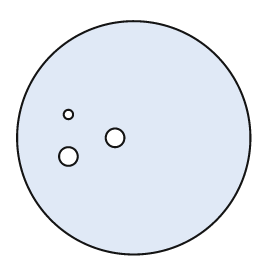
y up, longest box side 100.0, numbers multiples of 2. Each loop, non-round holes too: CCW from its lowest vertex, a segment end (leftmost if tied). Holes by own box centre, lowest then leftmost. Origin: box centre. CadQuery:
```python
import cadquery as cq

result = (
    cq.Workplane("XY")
    .moveTo(0.0, 0.0)
    .circle(50.0)
    .moveTo(-28.0, -8.0)
    .circle(4.0)
    .moveTo(-8.0, 0.0)
    .circle(4.0)
    .moveTo(-28.0, 10.0)
    .circle(2.0)
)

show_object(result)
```